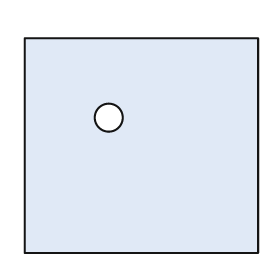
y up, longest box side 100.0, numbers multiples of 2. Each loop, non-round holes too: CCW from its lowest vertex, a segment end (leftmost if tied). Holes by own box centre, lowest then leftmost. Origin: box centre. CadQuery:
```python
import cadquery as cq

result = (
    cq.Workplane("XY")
    .moveTo(-50.0, -46.0)
    .lineTo(50.0, -46.0)
    .lineTo(50.0, 46.0)
    .lineTo(-50.0, 46.0)
    .close()
    .moveTo(-14.0, 12.0)
    .circle(6.0)
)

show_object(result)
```